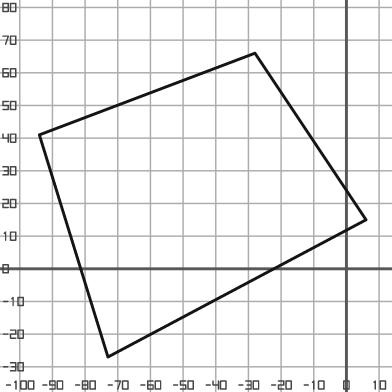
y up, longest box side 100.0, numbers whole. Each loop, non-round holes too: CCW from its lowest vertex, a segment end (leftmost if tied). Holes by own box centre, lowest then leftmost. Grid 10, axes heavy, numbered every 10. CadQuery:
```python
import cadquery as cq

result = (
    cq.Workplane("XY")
    .moveTo(-73.0, -27.0)
    .lineTo(6.0, 15.0)
    .lineTo(-28.0, 66.0)
    .lineTo(-94.0, 41.0)
    .close()
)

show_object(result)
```